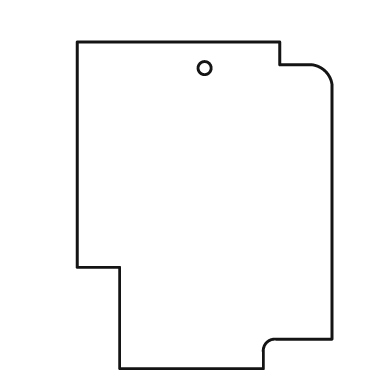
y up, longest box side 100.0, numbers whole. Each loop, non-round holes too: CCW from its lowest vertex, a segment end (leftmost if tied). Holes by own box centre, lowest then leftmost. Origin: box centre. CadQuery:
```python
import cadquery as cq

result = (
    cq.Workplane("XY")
    .moveTo(-26.0, -50.0)
    .lineTo(18.0, -50.0)
    .lineTo(18.0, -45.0)
    .threePointArc((19.0, -42.0), (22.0, -41.0))
    .lineTo(39.0, -41.0)
    .lineTo(39.0, 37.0)
    .threePointArc((37.0, 41.0), (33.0, 43.0))
    .lineTo(23.0, 43.0)
    .lineTo(23.0, 50.0)
    .lineTo(-39.0, 50.0)
    .lineTo(-39.0, -19.0)
    .lineTo(-26.0, -19.0)
    .close()
    .moveTo(0.0, 42.0)
    .circle(2.0)
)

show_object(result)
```